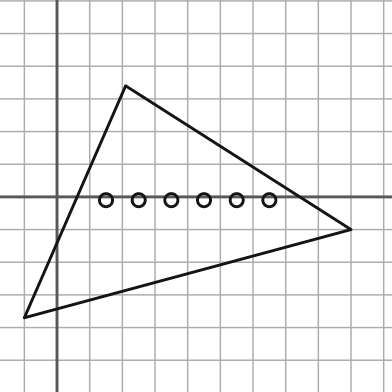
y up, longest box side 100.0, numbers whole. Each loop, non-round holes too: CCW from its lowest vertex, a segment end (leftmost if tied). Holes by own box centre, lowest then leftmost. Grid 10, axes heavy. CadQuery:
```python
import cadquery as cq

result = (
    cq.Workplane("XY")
    .moveTo(-10.0, -37.0)
    .lineTo(90.0, -10.0)
    .lineTo(21.0, 34.0)
    .close()
    .moveTo(15.0, -1.0)
    .circle(2.0)
    .moveTo(25.0, -1.0)
    .circle(2.0)
    .moveTo(35.0, -1.0)
    .circle(2.0)
    .moveTo(45.0, -1.0)
    .circle(2.0)
    .moveTo(55.0, -1.0)
    .circle(2.0)
    .moveTo(65.0, -1.0)
    .circle(2.0)
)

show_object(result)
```